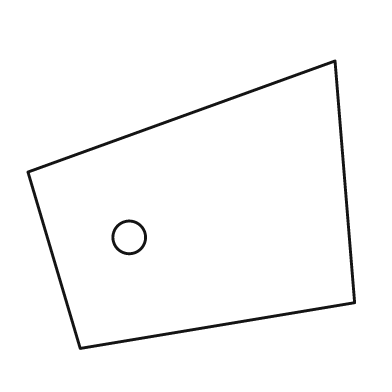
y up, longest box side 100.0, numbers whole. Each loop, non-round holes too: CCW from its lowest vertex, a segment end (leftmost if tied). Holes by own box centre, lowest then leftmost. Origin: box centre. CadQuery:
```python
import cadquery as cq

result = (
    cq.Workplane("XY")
    .moveTo(-34.0, -44.0)
    .lineTo(50.0, -30.0)
    .lineTo(44.0, 44.0)
    .lineTo(-50.0, 10.0)
    .close()
    .moveTo(-19.0, -10.0)
    .circle(5.0)
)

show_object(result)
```